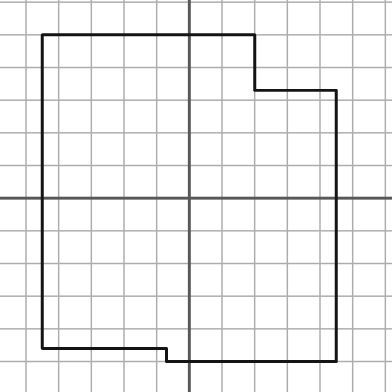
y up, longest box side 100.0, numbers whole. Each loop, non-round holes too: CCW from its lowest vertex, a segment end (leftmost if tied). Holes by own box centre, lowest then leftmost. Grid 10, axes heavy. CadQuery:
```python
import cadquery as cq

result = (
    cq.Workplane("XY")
    .moveTo(-7.0, -50.0)
    .lineTo(45.0, -50.0)
    .lineTo(45.0, 33.0)
    .lineTo(20.0, 33.0)
    .lineTo(20.0, 50.0)
    .lineTo(-45.0, 50.0)
    .lineTo(-45.0, -46.0)
    .lineTo(-7.0, -46.0)
    .close()
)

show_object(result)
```